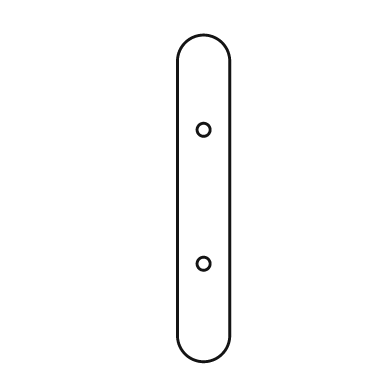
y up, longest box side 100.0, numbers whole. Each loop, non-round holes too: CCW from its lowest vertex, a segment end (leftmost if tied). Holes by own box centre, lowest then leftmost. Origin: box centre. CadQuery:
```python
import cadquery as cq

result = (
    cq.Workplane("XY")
    .moveTo(-8.0, -42.0)
    .threePointArc((0.0, -50.0), (8.0, -42.0))
    .lineTo(8.0, 42.0)
    .threePointArc((0.0, 50.0), (-8.0, 42.0))
    .close()
    .moveTo(0.0, -20.0)
    .circle(2.0)
    .moveTo(0.0, 21.0)
    .circle(2.0)
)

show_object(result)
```